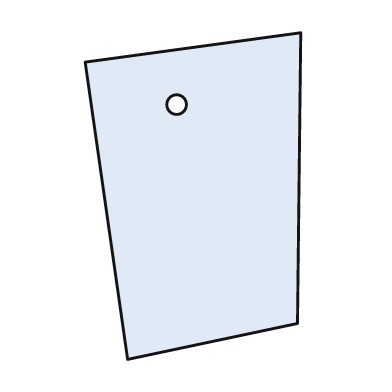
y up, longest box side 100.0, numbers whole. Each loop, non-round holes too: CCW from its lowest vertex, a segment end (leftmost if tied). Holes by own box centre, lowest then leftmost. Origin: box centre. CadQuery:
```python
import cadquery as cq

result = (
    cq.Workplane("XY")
    .moveTo(-20.0, -50.0)
    .lineTo(32.0, -39.0)
    .lineTo(33.0, 50.0)
    .lineTo(-33.0, 41.0)
    .close()
    .moveTo(-5.0, 28.0)
    .circle(3.0)
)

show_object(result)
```